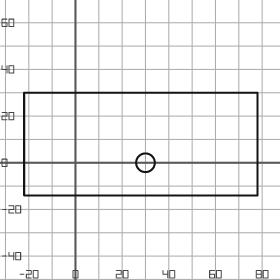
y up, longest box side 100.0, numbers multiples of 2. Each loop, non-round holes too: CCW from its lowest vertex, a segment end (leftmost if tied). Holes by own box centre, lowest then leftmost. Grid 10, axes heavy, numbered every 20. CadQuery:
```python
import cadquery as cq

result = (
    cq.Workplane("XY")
    .moveTo(-22.0, -14.0)
    .lineTo(78.0, -14.0)
    .lineTo(78.0, 30.0)
    .lineTo(-22.0, 30.0)
    .close()
    .moveTo(30.0, 0.0)
    .circle(4.0)
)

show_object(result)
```